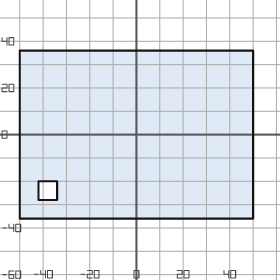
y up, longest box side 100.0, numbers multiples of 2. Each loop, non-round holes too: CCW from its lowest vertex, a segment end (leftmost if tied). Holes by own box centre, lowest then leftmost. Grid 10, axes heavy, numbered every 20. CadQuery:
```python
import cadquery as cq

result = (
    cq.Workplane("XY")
    .moveTo(-50.0, -36.0)
    .lineTo(50.0, -36.0)
    .lineTo(50.0, 36.0)
    .lineTo(-50.0, 36.0)
    .close()
    .moveTo(-42.0, -28.0)
    .lineTo(-34.0, -28.0)
    .lineTo(-34.0, -20.0)
    .lineTo(-42.0, -20.0)
    .close()
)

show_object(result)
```